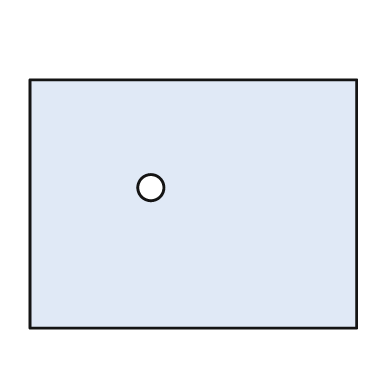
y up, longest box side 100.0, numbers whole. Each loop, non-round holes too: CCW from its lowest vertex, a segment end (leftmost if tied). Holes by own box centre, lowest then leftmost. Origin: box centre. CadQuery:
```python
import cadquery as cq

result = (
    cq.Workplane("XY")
    .moveTo(-50.0, -38.0)
    .lineTo(50.0, -38.0)
    .lineTo(50.0, 38.0)
    .lineTo(-50.0, 38.0)
    .close()
    .moveTo(-13.0, 5.0)
    .circle(4.0)
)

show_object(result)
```